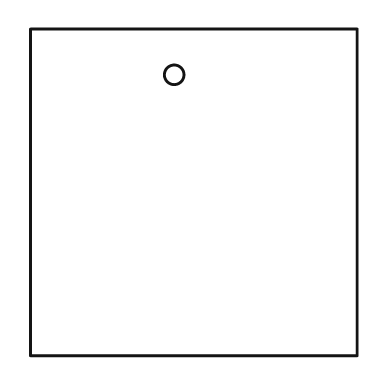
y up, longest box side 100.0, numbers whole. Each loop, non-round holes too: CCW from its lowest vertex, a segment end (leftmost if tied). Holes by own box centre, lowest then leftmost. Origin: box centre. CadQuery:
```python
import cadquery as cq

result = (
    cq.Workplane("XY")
    .moveTo(-50.0, -50.0)
    .lineTo(50.0, -50.0)
    .lineTo(50.0, 50.0)
    .lineTo(-50.0, 50.0)
    .close()
    .moveTo(-6.0, 36.0)
    .circle(3.0)
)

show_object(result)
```